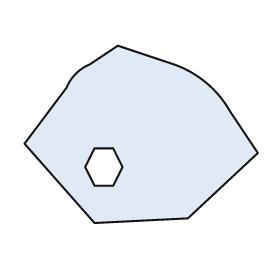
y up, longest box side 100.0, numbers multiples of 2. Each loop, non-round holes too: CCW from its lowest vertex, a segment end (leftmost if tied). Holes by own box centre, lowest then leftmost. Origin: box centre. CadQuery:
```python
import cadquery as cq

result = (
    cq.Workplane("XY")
    .moveTo(-20.0, -38.0)
    .lineTo(20.0, -36.0)
    .lineTo(50.0, -8.0)
    .lineTo(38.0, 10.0)
    .threePointArc((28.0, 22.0), (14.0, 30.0))
    .lineTo(-10.0, 38.0)
    .lineTo(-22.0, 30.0)
    .threePointArc((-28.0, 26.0), (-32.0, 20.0))
    .lineTo(-50.0, -4.0)
    .close()
    .moveTo(-20.0, -22.0)
    .lineTo(-12.0, -22.0)
    .lineTo(-8.0, -14.0)
    .lineTo(-12.0, -6.0)
    .lineTo(-20.0, -6.0)
    .lineTo(-24.0, -14.0)
    .close()
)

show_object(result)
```